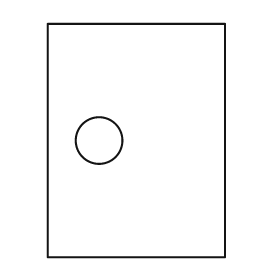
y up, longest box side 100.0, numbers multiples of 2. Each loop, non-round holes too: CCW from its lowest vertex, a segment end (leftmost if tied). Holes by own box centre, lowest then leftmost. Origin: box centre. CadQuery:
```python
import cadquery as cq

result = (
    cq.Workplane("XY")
    .moveTo(-38.0, -50.0)
    .lineTo(38.0, -50.0)
    .lineTo(38.0, 50.0)
    .lineTo(-38.0, 50.0)
    .close()
    .moveTo(-16.0, 0.0)
    .circle(10.0)
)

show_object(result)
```